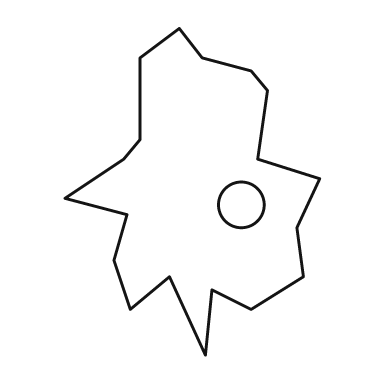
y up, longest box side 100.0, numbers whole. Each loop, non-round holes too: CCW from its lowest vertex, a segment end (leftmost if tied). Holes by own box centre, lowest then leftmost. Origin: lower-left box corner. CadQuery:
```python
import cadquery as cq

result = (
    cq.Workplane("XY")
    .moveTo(43.0, 0.0)
    .lineTo(45.0, 20.0)
    .lineTo(57.0, 14.0)
    .lineTo(73.0, 24.0)
    .lineTo(71.0, 39.0)
    .lineTo(78.0, 54.0)
    .lineTo(59.0, 60.0)
    .lineTo(62.0, 81.0)
    .lineTo(57.0, 87.0)
    .lineTo(42.0, 91.0)
    .lineTo(35.0, 100.0)
    .lineTo(23.0, 91.0)
    .lineTo(23.0, 66.0)
    .lineTo(18.0, 60.0)
    .lineTo(0.0, 48.0)
    .lineTo(19.0, 43.0)
    .lineTo(15.0, 29.0)
    .lineTo(20.0, 14.0)
    .lineTo(32.0, 24.0)
    .close()
    .moveTo(54.0, 46.0)
    .circle(7.0)
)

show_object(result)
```